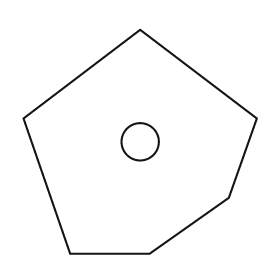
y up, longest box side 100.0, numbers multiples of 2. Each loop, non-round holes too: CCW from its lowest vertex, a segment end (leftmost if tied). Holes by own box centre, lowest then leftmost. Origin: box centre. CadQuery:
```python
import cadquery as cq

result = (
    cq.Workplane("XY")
    .moveTo(-30.0, -48.0)
    .lineTo(4.0, -48.0)
    .lineTo(38.0, -24.0)
    .lineTo(50.0, 10.0)
    .lineTo(0.0, 48.0)
    .lineTo(-50.0, 10.0)
    .close()
    .moveTo(0.0, 0.0)
    .circle(8.0)
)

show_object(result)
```